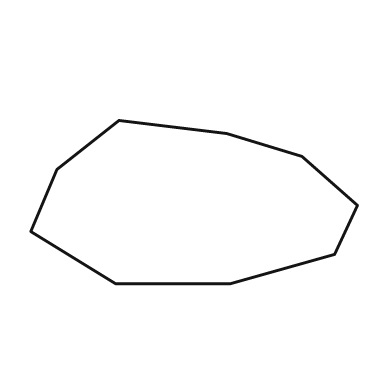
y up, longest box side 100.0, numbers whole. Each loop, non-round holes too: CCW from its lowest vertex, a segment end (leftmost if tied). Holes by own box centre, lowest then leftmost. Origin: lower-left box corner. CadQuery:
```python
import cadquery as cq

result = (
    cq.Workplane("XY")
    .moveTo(26.0, 0.0)
    .lineTo(61.0, 0.0)
    .lineTo(93.0, 9.0)
    .lineTo(100.0, 24.0)
    .lineTo(83.0, 39.0)
    .lineTo(60.0, 46.0)
    .lineTo(27.0, 50.0)
    .lineTo(8.0, 35.0)
    .lineTo(0.0, 16.0)
    .close()
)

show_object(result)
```